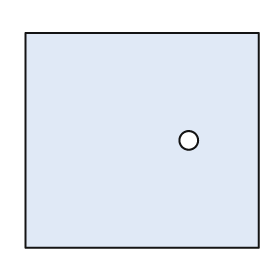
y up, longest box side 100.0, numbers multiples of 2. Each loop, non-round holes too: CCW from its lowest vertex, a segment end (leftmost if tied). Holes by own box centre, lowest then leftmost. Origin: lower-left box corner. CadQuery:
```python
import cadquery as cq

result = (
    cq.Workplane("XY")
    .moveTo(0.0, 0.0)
    .lineTo(100.0, 0.0)
    .lineTo(100.0, 92.0)
    .lineTo(0.0, 92.0)
    .close()
    .moveTo(70.0, 46.0)
    .circle(4.0)
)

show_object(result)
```